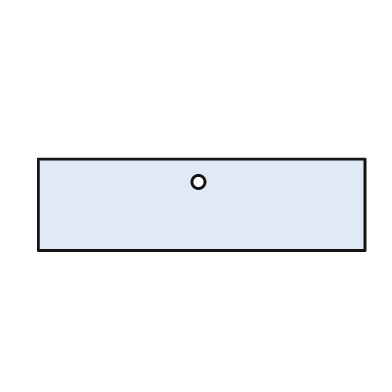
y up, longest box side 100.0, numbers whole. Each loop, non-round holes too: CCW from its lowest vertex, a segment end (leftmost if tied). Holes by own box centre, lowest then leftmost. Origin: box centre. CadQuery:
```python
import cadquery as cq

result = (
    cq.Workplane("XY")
    .moveTo(-50.0, -14.0)
    .lineTo(50.0, -14.0)
    .lineTo(50.0, 14.0)
    .lineTo(-50.0, 14.0)
    .close()
    .moveTo(-1.0, 7.0)
    .circle(2.0)
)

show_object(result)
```